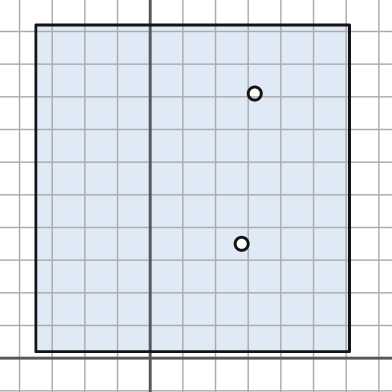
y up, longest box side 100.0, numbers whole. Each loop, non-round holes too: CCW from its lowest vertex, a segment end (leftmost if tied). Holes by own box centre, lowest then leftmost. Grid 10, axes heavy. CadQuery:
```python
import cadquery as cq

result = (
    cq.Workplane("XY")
    .moveTo(-35.0, 2.0)
    .lineTo(61.0, 2.0)
    .lineTo(61.0, 102.0)
    .lineTo(-35.0, 102.0)
    .close()
    .moveTo(28.0, 35.0)
    .circle(2.0)
    .moveTo(32.0, 81.0)
    .circle(2.0)
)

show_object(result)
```